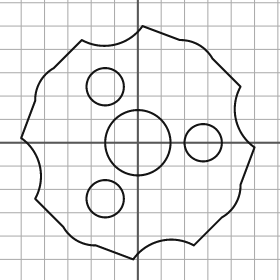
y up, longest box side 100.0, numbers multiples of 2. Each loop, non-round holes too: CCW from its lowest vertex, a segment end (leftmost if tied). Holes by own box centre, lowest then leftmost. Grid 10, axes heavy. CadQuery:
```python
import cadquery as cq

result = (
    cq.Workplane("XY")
    .moveTo(-2.0, -50.0)
    .threePointArc((10.0, -42.0), (24.0, -44.0))
    .lineTo(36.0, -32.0)
    .threePointArc((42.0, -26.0), (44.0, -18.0))
    .lineTo(50.0, -2.0)
    .threePointArc((42.0, 10.0), (44.0, 24.0))
    .lineTo(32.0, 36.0)
    .threePointArc((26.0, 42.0), (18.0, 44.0))
    .lineTo(2.0, 50.0)
    .threePointArc((-10.0, 42.0), (-24.0, 44.0))
    .lineTo(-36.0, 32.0)
    .threePointArc((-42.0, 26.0), (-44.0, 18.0))
    .lineTo(-50.0, 2.0)
    .threePointArc((-42.0, -10.0), (-44.0, -24.0))
    .lineTo(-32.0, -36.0)
    .threePointArc((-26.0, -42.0), (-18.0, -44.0))
    .close()
    .moveTo(-14.0, -24.0)
    .circle(8.0)
    .moveTo(0.0, 0.0)
    .circle(14.0)
    .moveTo(28.0, 0.0)
    .circle(8.0)
    .moveTo(-14.0, 24.0)
    .circle(8.0)
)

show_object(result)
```